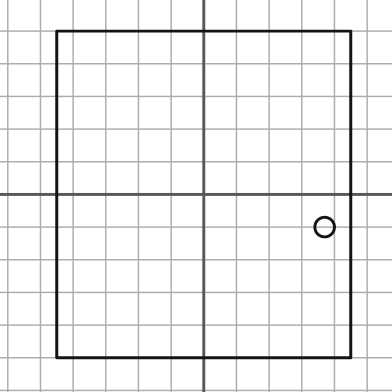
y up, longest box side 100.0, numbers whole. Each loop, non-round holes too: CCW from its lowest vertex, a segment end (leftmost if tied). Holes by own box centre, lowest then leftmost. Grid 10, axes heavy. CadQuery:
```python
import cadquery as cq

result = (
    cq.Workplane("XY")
    .moveTo(-45.0, -50.0)
    .lineTo(45.0, -50.0)
    .lineTo(45.0, 50.0)
    .lineTo(-45.0, 50.0)
    .close()
    .moveTo(37.0, -10.0)
    .circle(3.0)
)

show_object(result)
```